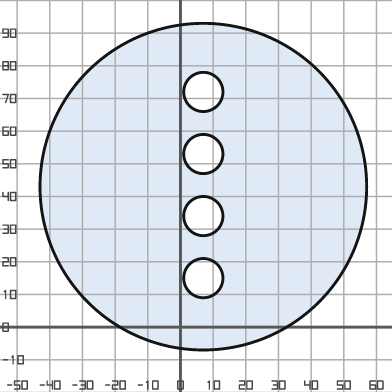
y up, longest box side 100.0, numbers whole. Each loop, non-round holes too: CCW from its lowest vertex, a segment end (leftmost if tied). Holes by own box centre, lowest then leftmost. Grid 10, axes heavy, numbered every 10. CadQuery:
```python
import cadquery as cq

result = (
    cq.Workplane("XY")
    .moveTo(7.0, 43.0)
    .circle(50.0)
    .moveTo(7.0, 15.0)
    .circle(6.0)
    .moveTo(7.0, 34.0)
    .circle(6.0)
    .moveTo(7.0, 53.0)
    .circle(6.0)
    .moveTo(7.0, 72.0)
    .circle(6.0)
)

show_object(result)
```